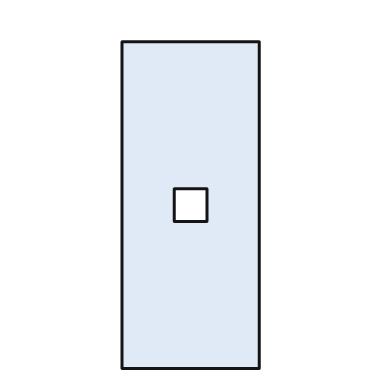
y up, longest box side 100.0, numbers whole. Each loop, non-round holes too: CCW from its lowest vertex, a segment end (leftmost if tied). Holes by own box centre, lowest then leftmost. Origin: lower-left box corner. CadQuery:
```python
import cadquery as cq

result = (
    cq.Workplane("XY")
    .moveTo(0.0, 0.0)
    .lineTo(42.0, 0.0)
    .lineTo(42.0, 100.0)
    .lineTo(0.0, 100.0)
    .close()
    .moveTo(16.0, 45.0)
    .lineTo(26.0, 45.0)
    .lineTo(26.0, 55.0)
    .lineTo(16.0, 55.0)
    .close()
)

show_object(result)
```